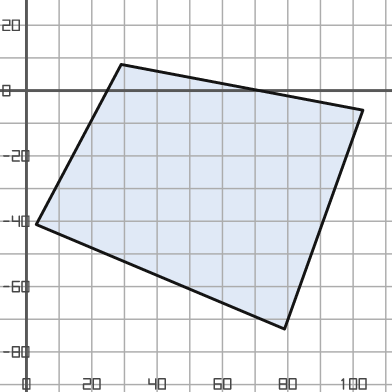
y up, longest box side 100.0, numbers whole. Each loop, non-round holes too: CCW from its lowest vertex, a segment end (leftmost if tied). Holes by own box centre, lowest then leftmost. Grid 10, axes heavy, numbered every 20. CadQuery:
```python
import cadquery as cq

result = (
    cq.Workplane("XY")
    .moveTo(79.0, -73.0)
    .lineTo(103.0, -6.0)
    .lineTo(29.0, 8.0)
    .lineTo(3.0, -41.0)
    .close()
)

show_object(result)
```